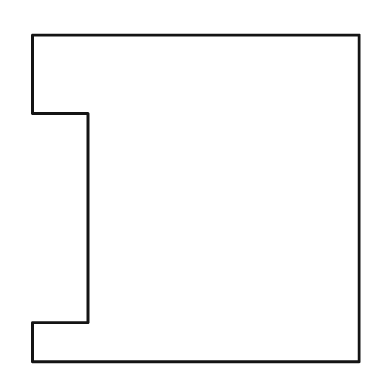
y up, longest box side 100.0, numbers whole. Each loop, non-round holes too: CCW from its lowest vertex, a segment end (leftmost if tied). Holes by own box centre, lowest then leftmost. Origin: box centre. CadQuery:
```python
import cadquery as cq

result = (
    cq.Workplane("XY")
    .moveTo(-50.0, -50.0)
    .lineTo(50.0, -50.0)
    .lineTo(50.0, 50.0)
    .lineTo(-50.0, 50.0)
    .lineTo(-50.0, 26.0)
    .lineTo(-33.0, 26.0)
    .lineTo(-33.0, -38.0)
    .lineTo(-50.0, -38.0)
    .close()
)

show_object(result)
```